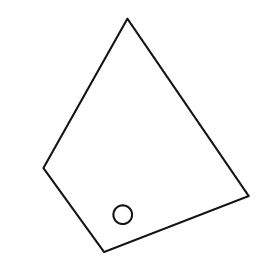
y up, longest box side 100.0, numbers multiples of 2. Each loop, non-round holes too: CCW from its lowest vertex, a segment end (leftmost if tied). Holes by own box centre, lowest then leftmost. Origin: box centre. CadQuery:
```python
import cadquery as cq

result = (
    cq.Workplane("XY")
    .moveTo(-18.0, -50.0)
    .lineTo(44.0, -26.0)
    .lineTo(-8.0, 50.0)
    .lineTo(-44.0, -14.0)
    .close()
    .moveTo(-10.0, -34.0)
    .circle(4.0)
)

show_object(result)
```